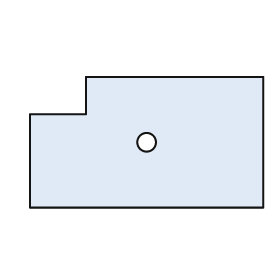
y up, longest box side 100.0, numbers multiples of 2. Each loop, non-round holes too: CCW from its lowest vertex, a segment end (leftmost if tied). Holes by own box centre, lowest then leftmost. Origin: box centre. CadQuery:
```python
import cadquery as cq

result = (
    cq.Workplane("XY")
    .moveTo(-50.0, -28.0)
    .lineTo(50.0, -28.0)
    .lineTo(50.0, 28.0)
    .lineTo(-26.0, 28.0)
    .lineTo(-26.0, 12.0)
    .lineTo(-50.0, 12.0)
    .close()
    .moveTo(0.0, 0.0)
    .circle(4.0)
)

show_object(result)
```